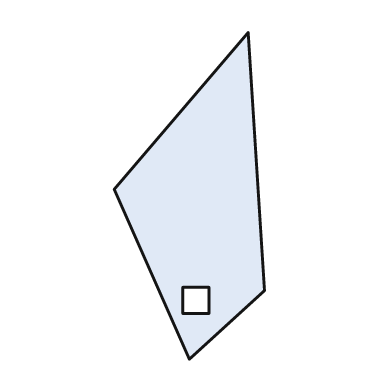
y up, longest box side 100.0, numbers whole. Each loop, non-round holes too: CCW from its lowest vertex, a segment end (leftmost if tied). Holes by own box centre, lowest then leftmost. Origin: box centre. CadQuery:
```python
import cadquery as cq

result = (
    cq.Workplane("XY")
    .moveTo(0.0, -50.0)
    .lineTo(23.0, -29.0)
    .lineTo(18.0, 50.0)
    .lineTo(-23.0, 2.0)
    .close()
    .moveTo(-2.0, -36.0)
    .lineTo(6.0, -36.0)
    .lineTo(6.0, -28.0)
    .lineTo(-2.0, -28.0)
    .close()
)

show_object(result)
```